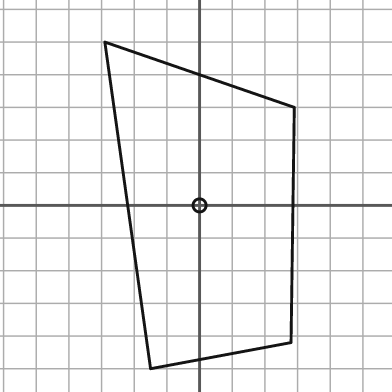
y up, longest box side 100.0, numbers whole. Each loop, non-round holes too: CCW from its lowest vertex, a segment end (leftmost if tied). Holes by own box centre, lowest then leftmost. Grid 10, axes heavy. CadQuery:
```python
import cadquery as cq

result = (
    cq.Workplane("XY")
    .moveTo(-15.0, -50.0)
    .lineTo(28.0, -42.0)
    .lineTo(29.0, 30.0)
    .lineTo(-29.0, 50.0)
    .close()
    .moveTo(0.0, 0.0)
    .circle(2.0)
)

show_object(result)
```